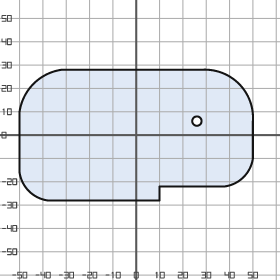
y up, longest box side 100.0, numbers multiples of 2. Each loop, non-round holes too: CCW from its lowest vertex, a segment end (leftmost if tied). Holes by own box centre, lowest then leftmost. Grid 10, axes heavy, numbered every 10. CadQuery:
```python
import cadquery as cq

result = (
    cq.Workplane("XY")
    .moveTo(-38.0, -28.0)
    .lineTo(10.0, -28.0)
    .lineTo(10.0, -22.0)
    .lineTo(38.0, -22.0)
    .threePointArc((46.0, -18.0), (50.0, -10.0))
    .lineTo(50.0, 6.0)
    .threePointArc((44.0, 22.0), (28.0, 28.0))
    .lineTo(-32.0, 28.0)
    .threePointArc((-44.0, 22.0), (-50.0, 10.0))
    .lineTo(-50.0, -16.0)
    .threePointArc((-46.0, -24.0), (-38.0, -28.0))
    .close()
    .moveTo(26.0, 6.0)
    .circle(2.0)
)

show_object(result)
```